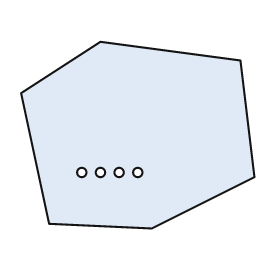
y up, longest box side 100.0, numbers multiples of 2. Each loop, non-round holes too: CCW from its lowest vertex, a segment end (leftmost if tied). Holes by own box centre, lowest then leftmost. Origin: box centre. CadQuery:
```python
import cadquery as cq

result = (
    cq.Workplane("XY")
    .moveTo(6.0, -40.0)
    .lineTo(50.0, -18.0)
    .lineTo(44.0, 32.0)
    .lineTo(-16.0, 40.0)
    .lineTo(-50.0, 18.0)
    .lineTo(-38.0, -38.0)
    .close()
    .moveTo(-24.0, -16.0)
    .circle(2.0)
    .moveTo(-16.0, -16.0)
    .circle(2.0)
    .moveTo(-8.0, -16.0)
    .circle(2.0)
    .moveTo(0.0, -16.0)
    .circle(2.0)
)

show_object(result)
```